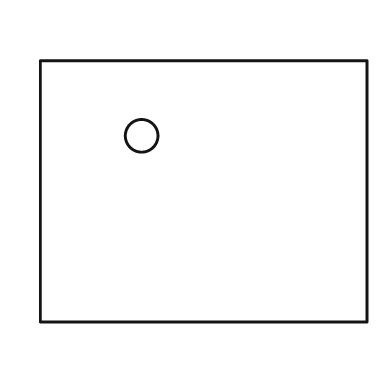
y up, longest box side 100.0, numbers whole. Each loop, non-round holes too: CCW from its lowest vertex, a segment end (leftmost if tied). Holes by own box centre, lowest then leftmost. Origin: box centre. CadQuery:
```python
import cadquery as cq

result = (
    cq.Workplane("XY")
    .moveTo(-50.0, -40.0)
    .lineTo(50.0, -40.0)
    .lineTo(50.0, 40.0)
    .lineTo(-50.0, 40.0)
    .close()
    .moveTo(-19.0, 17.0)
    .circle(5.0)
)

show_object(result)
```